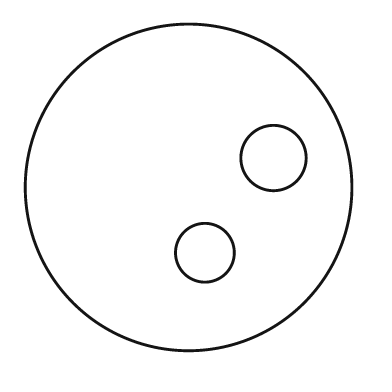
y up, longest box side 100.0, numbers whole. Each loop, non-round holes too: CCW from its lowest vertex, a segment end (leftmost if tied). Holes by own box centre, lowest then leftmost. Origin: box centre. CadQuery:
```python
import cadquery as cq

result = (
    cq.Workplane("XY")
    .moveTo(0.0, 0.0)
    .circle(50.0)
    .moveTo(5.0, -20.0)
    .circle(9.0)
    .moveTo(26.0, 9.0)
    .circle(10.0)
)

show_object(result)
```